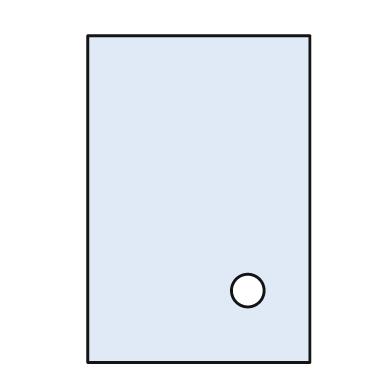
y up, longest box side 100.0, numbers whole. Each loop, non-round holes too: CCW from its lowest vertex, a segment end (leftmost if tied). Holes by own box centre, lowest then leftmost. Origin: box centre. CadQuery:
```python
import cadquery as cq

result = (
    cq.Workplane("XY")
    .moveTo(-34.0, -50.0)
    .lineTo(34.0, -50.0)
    .lineTo(34.0, 50.0)
    .lineTo(-34.0, 50.0)
    .close()
    .moveTo(15.0, -28.0)
    .circle(5.0)
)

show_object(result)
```